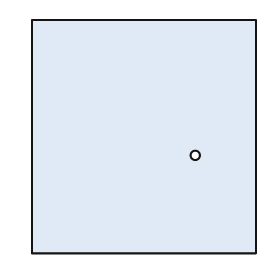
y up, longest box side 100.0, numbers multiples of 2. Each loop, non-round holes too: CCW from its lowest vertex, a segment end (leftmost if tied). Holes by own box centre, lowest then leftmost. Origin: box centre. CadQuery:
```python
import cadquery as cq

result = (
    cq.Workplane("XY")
    .moveTo(-48.0, -50.0)
    .lineTo(48.0, -50.0)
    .lineTo(48.0, 50.0)
    .lineTo(-48.0, 50.0)
    .close()
    .moveTo(22.0, -8.0)
    .circle(2.0)
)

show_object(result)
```